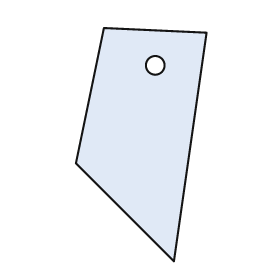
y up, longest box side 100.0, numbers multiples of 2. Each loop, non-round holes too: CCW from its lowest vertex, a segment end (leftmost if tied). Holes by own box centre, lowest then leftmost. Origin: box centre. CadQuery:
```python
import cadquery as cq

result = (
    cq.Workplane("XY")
    .moveTo(14.0, -50.0)
    .lineTo(28.0, 48.0)
    .lineTo(-16.0, 50.0)
    .lineTo(-28.0, -8.0)
    .close()
    .moveTo(6.0, 34.0)
    .circle(4.0)
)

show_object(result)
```